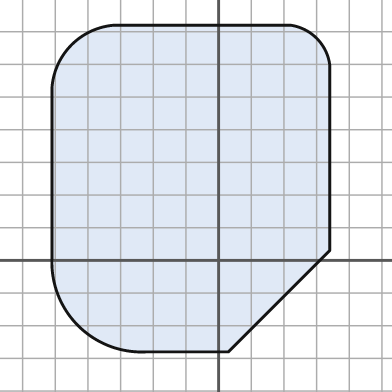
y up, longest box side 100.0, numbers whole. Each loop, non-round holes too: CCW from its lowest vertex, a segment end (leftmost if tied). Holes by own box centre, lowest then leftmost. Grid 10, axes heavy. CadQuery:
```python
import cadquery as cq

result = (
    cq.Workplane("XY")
    .moveTo(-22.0, -28.0)
    .lineTo(3.0, -28.0)
    .lineTo(34.0, 3.0)
    .lineTo(34.0, 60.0)
    .threePointArc((30.0, 68.0), (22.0, 72.0))
    .lineTo(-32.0, 72.0)
    .threePointArc((-45.0, 66.0), (-51.0, 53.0))
    .lineTo(-51.0, 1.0)
    .threePointArc((-43.0, -20.0), (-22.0, -28.0))
    .close()
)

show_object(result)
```